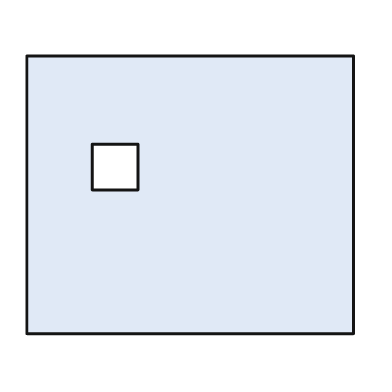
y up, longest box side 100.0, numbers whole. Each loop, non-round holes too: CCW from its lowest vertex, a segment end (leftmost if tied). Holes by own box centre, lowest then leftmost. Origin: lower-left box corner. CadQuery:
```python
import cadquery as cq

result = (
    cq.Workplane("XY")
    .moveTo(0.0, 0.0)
    .lineTo(100.0, 0.0)
    .lineTo(100.0, 85.0)
    .lineTo(0.0, 85.0)
    .close()
    .moveTo(20.0, 44.0)
    .lineTo(34.0, 44.0)
    .lineTo(34.0, 58.0)
    .lineTo(20.0, 58.0)
    .close()
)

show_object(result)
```